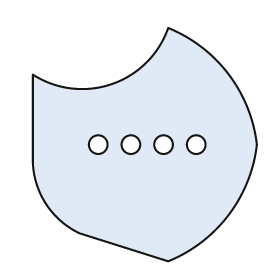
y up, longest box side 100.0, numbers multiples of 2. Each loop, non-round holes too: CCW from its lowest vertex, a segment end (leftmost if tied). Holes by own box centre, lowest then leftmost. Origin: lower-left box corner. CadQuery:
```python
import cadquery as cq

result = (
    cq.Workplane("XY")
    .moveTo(58.0, 0.0)
    .threePointArc((84.0, 20.0), (96.0, 50.0))
    .threePointArc((84.0, 80.0), (58.0, 100.0))
    .threePointArc((34.0, 76.0), (0.0, 80.0))
    .lineTo(0.0, 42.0)
    .threePointArc((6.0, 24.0), (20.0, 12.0))
    .close()
    .moveTo(28.0, 50.0)
    .circle(4.0)
    .moveTo(42.0, 50.0)
    .circle(4.0)
    .moveTo(56.0, 50.0)
    .circle(4.0)
    .moveTo(70.0, 50.0)
    .circle(4.0)
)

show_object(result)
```